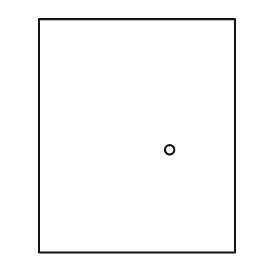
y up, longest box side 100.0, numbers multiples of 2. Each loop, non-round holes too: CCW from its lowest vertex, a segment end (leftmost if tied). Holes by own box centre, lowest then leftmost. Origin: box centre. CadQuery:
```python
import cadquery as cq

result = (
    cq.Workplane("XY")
    .moveTo(-42.0, -50.0)
    .lineTo(42.0, -50.0)
    .lineTo(42.0, 50.0)
    .lineTo(-42.0, 50.0)
    .close()
    .moveTo(14.0, -6.0)
    .circle(2.0)
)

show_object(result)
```